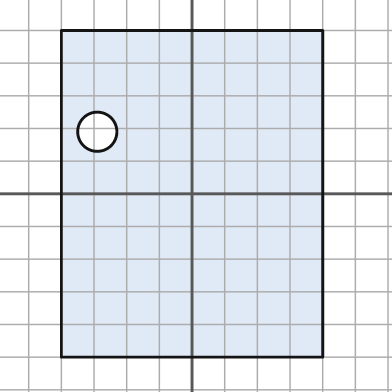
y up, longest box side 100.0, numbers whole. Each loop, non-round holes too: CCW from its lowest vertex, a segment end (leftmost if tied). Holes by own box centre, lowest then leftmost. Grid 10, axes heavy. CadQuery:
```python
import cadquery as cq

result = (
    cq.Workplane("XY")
    .moveTo(-40.0, -50.0)
    .lineTo(40.0, -50.0)
    .lineTo(40.0, 50.0)
    .lineTo(-40.0, 50.0)
    .close()
    .moveTo(-29.0, 19.0)
    .circle(6.0)
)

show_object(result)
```